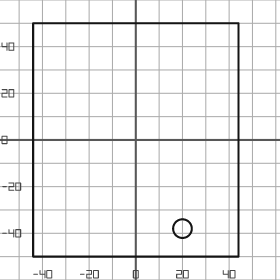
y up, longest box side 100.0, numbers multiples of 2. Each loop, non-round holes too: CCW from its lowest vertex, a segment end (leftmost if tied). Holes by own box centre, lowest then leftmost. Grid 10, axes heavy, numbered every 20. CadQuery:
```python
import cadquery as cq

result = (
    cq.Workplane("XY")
    .moveTo(-44.0, -50.0)
    .lineTo(44.0, -50.0)
    .lineTo(44.0, 50.0)
    .lineTo(-44.0, 50.0)
    .close()
    .moveTo(20.0, -38.0)
    .circle(4.0)
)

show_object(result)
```